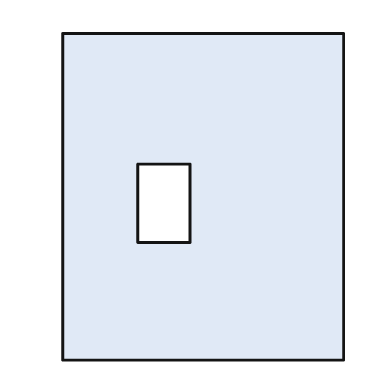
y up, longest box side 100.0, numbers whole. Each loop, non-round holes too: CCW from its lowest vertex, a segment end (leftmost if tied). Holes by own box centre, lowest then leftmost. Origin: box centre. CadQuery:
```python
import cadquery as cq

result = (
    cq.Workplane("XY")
    .moveTo(-43.0, -50.0)
    .lineTo(43.0, -50.0)
    .lineTo(43.0, 50.0)
    .lineTo(-43.0, 50.0)
    .close()
    .moveTo(-20.0, -14.0)
    .lineTo(-4.0, -14.0)
    .lineTo(-4.0, 10.0)
    .lineTo(-20.0, 10.0)
    .close()
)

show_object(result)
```